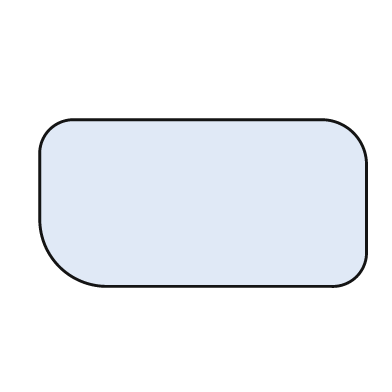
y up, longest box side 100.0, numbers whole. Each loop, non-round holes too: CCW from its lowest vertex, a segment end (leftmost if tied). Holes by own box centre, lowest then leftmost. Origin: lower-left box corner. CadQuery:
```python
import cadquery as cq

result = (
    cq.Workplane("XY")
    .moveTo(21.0, 0.0)
    .lineTo(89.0, 0.0)
    .threePointArc((97.0, 3.0), (100.0, 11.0))
    .lineTo(100.0, 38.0)
    .threePointArc((96.0, 47.0), (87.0, 51.0))
    .lineTo(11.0, 51.0)
    .threePointArc((3.0, 48.0), (0.0, 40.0))
    .lineTo(0.0, 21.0)
    .threePointArc((6.0, 6.0), (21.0, 0.0))
    .close()
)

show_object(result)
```